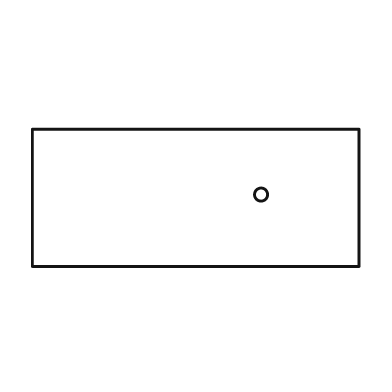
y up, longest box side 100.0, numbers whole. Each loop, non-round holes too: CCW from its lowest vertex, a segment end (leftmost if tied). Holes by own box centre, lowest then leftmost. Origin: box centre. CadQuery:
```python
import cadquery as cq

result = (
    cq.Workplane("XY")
    .moveTo(-50.0, -21.0)
    .lineTo(50.0, -21.0)
    .lineTo(50.0, 21.0)
    .lineTo(-50.0, 21.0)
    .close()
    .moveTo(20.0, 1.0)
    .circle(2.0)
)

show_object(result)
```